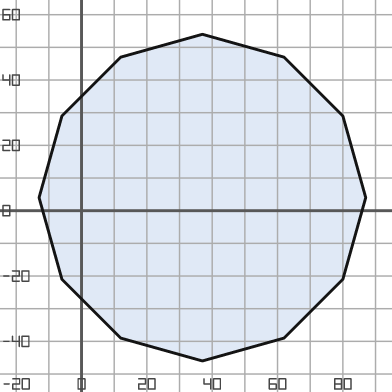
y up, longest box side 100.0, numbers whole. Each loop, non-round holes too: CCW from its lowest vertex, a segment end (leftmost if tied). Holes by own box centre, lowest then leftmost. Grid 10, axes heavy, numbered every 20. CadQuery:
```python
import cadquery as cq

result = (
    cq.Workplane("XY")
    .moveTo(37.0, -46.0)
    .lineTo(62.0, -39.0)
    .lineTo(80.0, -21.0)
    .lineTo(87.0, 4.0)
    .lineTo(80.0, 29.0)
    .lineTo(62.0, 47.0)
    .lineTo(37.0, 54.0)
    .lineTo(12.0, 47.0)
    .lineTo(-6.0, 29.0)
    .lineTo(-13.0, 4.0)
    .lineTo(-6.0, -21.0)
    .lineTo(12.0, -39.0)
    .close()
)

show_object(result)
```